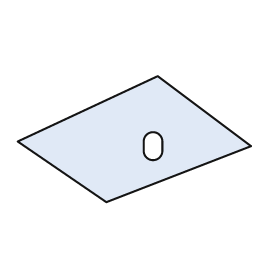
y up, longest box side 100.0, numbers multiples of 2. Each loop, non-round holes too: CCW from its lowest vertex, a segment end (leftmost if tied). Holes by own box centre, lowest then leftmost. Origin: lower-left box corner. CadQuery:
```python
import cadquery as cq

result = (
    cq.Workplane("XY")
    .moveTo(38.0, 0.0)
    .lineTo(100.0, 24.0)
    .lineTo(60.0, 54.0)
    .lineTo(0.0, 26.0)
    .close()
    .moveTo(54.0, 22.0)
    .threePointArc((58.0, 18.0), (62.0, 22.0))
    .lineTo(62.0, 26.0)
    .threePointArc((58.0, 30.0), (54.0, 26.0))
    .close()
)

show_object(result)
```